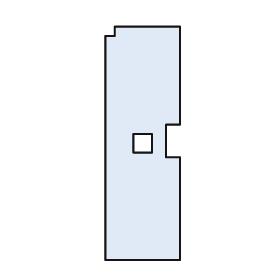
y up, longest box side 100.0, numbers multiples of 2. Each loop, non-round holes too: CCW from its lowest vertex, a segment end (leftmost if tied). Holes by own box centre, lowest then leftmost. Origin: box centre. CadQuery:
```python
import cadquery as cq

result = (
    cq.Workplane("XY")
    .moveTo(-16.0, -50.0)
    .lineTo(16.0, -50.0)
    .lineTo(16.0, -6.0)
    .lineTo(10.0, -6.0)
    .lineTo(10.0, 8.0)
    .lineTo(16.0, 8.0)
    .lineTo(16.0, 50.0)
    .lineTo(-12.0, 50.0)
    .lineTo(-12.0, 46.0)
    .lineTo(-16.0, 46.0)
    .close()
    .moveTo(-4.0, -4.0)
    .lineTo(4.0, -4.0)
    .lineTo(4.0, 4.0)
    .lineTo(-4.0, 4.0)
    .close()
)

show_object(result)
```